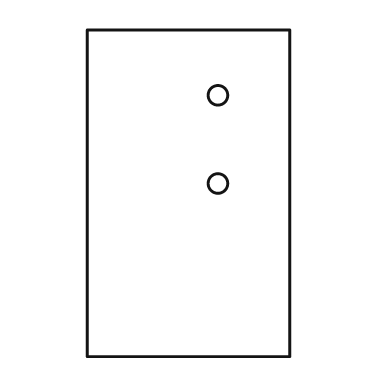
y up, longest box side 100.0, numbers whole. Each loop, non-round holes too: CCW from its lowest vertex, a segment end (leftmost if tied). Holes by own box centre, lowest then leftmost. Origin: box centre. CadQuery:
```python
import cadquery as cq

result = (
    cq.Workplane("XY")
    .moveTo(-31.0, -50.0)
    .lineTo(31.0, -50.0)
    .lineTo(31.0, 50.0)
    .lineTo(-31.0, 50.0)
    .close()
    .moveTo(9.0, 3.0)
    .circle(3.0)
    .moveTo(9.0, 30.0)
    .circle(3.0)
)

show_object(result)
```